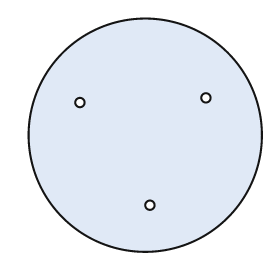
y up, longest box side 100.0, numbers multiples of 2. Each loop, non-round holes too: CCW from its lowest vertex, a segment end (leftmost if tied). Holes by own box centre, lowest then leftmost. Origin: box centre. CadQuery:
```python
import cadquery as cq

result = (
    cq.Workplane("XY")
    .moveTo(0.0, 0.0)
    .circle(50.0)
    .moveTo(2.0, -30.0)
    .circle(2.0)
    .moveTo(-28.0, 14.0)
    .circle(2.0)
    .moveTo(26.0, 16.0)
    .circle(2.0)
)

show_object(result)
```